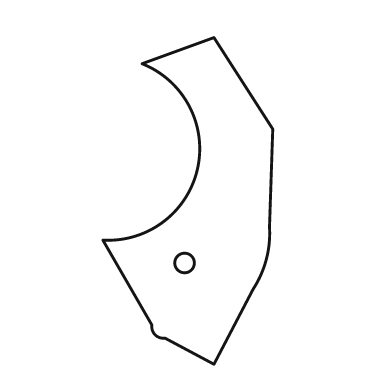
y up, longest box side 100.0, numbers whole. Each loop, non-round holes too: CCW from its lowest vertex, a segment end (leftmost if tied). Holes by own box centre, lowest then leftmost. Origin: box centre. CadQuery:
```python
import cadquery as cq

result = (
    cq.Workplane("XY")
    .moveTo(8.0, -50.0)
    .lineTo(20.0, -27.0)
    .threePointArc((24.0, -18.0), (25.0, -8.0))
    .lineTo(26.0, 22.0)
    .lineTo(8.0, 50.0)
    .lineTo(-14.0, 42.0)
    .threePointArc((3.0, 10.0), (-26.0, -12.0))
    .lineTo(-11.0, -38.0)
    .threePointArc((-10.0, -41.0), (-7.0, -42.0))
    .close()
    .moveTo(-1.0, -19.0)
    .circle(3.0)
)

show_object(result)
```